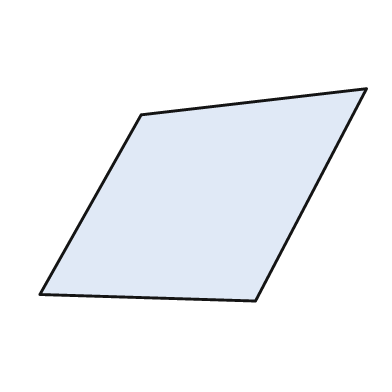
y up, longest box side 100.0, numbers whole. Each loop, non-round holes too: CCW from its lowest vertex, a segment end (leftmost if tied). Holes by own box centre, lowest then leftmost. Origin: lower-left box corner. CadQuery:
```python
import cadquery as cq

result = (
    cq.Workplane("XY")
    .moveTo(66.0, 0.0)
    .lineTo(100.0, 65.0)
    .lineTo(31.0, 57.0)
    .lineTo(0.0, 2.0)
    .close()
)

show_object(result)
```